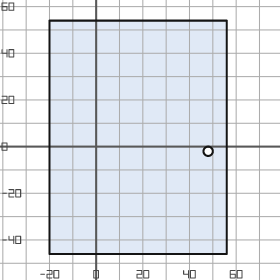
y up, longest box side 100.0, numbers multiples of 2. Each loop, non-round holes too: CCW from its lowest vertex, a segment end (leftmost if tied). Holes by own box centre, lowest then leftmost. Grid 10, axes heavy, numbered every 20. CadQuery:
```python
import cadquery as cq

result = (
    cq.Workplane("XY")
    .moveTo(-20.0, -46.0)
    .lineTo(56.0, -46.0)
    .lineTo(56.0, 54.0)
    .lineTo(-20.0, 54.0)
    .close()
    .moveTo(48.0, -2.0)
    .circle(2.0)
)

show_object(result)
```